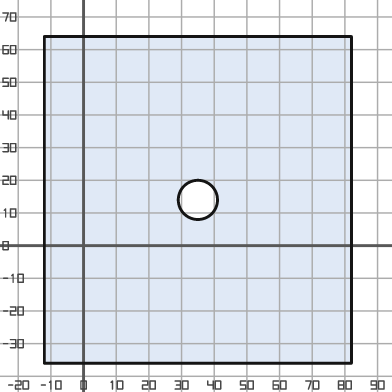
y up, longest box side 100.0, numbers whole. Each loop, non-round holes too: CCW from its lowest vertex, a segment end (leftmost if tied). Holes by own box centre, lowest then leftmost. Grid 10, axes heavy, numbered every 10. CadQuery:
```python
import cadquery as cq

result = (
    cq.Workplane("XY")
    .moveTo(-12.0, -36.0)
    .lineTo(82.0, -36.0)
    .lineTo(82.0, 64.0)
    .lineTo(-12.0, 64.0)
    .close()
    .moveTo(35.0, 14.0)
    .circle(6.0)
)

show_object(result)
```